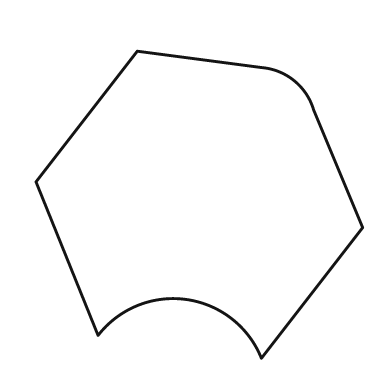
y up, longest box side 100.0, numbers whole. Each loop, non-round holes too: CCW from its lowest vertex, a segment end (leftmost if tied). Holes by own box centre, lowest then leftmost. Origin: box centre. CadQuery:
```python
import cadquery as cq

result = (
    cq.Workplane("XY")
    .moveTo(19.0, -47.0)
    .lineTo(50.0, -7.0)
    .lineTo(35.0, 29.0)
    .threePointArc((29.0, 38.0), (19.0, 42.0))
    .lineTo(-19.0, 47.0)
    .lineTo(-50.0, 7.0)
    .lineTo(-31.0, -40.0)
    .threePointArc((-4.0, -29.0), (19.0, -47.0))
    .close()
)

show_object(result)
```